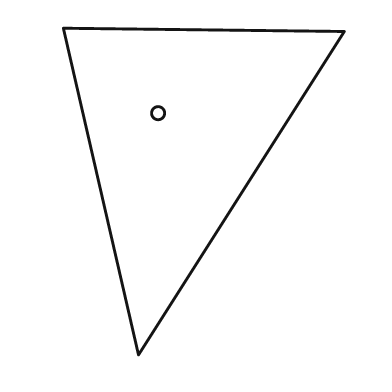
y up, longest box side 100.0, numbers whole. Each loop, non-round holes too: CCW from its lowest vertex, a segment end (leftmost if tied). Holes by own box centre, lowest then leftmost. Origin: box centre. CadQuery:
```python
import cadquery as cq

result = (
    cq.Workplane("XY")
    .moveTo(-20.0, -50.0)
    .lineTo(43.0, 49.0)
    .lineTo(-43.0, 50.0)
    .close()
    .moveTo(-14.0, 24.0)
    .circle(2.0)
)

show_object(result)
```